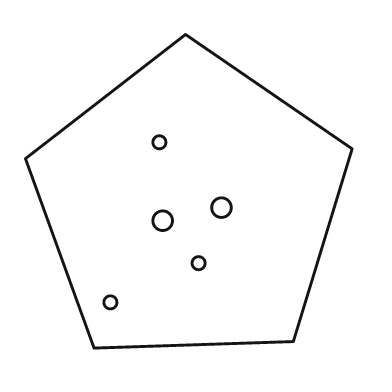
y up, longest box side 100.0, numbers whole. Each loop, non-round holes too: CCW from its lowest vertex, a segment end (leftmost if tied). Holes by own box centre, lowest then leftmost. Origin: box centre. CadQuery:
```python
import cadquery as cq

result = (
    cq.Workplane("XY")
    .moveTo(-29.0, -48.0)
    .lineTo(32.0, -46.0)
    .lineTo(50.0, 13.0)
    .lineTo(-1.0, 48.0)
    .lineTo(-50.0, 10.0)
    .close()
    .moveTo(-24.0, -34.0)
    .circle(2.0)
    .moveTo(3.0, -22.0)
    .circle(2.0)
    .moveTo(-8.0, -9.0)
    .circle(3.0)
    .moveTo(10.0, -5.0)
    .circle(3.0)
    .moveTo(-9.0, 15.0)
    .circle(2.0)
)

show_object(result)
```